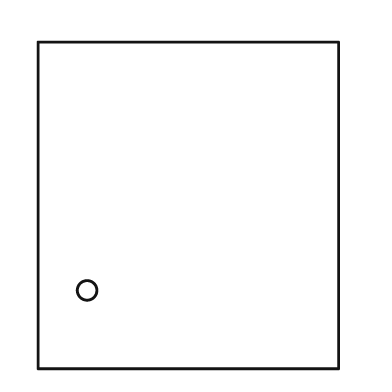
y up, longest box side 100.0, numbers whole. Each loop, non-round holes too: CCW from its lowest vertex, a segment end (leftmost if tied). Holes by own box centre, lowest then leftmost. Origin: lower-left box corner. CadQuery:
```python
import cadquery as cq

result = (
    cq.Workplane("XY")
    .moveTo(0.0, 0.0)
    .lineTo(92.0, 0.0)
    .lineTo(92.0, 100.0)
    .lineTo(0.0, 100.0)
    .close()
    .moveTo(15.0, 24.0)
    .circle(3.0)
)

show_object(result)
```